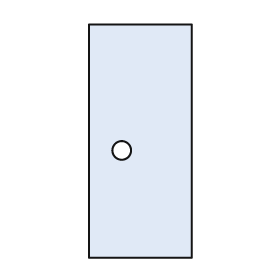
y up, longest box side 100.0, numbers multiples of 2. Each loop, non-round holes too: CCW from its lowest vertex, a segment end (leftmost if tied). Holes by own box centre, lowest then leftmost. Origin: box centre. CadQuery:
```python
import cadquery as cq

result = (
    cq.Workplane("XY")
    .moveTo(-22.0, -50.0)
    .lineTo(22.0, -50.0)
    .lineTo(22.0, 50.0)
    .lineTo(-22.0, 50.0)
    .close()
    .moveTo(-8.0, -4.0)
    .circle(4.0)
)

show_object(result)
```